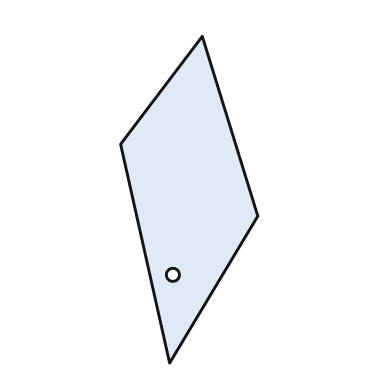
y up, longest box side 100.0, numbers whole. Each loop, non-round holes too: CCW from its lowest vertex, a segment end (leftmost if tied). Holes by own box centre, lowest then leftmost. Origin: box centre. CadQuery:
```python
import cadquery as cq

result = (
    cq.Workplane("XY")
    .moveTo(-6.0, -50.0)
    .lineTo(21.0, -5.0)
    .lineTo(4.0, 50.0)
    .lineTo(-21.0, 17.0)
    .close()
    .moveTo(-5.0, -23.0)
    .circle(2.0)
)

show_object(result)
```